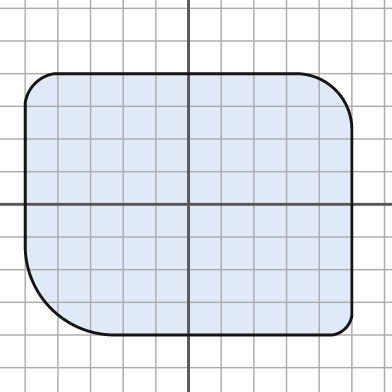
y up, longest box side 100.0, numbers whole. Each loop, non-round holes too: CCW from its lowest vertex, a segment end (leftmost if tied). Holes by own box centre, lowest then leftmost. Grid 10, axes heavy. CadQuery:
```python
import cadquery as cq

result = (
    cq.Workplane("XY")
    .moveTo(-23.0, -40.0)
    .lineTo(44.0, -40.0)
    .threePointArc((48.0, -38.0), (50.0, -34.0))
    .lineTo(50.0, 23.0)
    .threePointArc((45.0, 35.0), (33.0, 40.0))
    .lineTo(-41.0, 40.0)
    .threePointArc((-47.0, 37.0), (-50.0, 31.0))
    .lineTo(-50.0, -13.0)
    .threePointArc((-42.0, -32.0), (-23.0, -40.0))
    .close()
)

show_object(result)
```